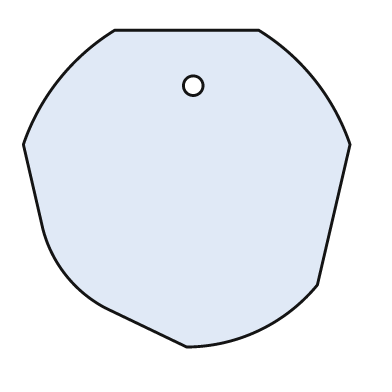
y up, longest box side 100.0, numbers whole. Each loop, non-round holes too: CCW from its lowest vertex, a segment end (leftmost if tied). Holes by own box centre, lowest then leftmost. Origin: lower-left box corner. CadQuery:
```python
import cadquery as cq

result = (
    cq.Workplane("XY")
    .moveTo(50.0, 0.0)
    .threePointArc((72.0, 5.0), (90.0, 19.0))
    .lineTo(100.0, 62.0)
    .threePointArc((89.0, 82.0), (72.0, 97.0))
    .lineTo(28.0, 97.0)
    .threePointArc((11.0, 82.0), (0.0, 62.0))
    .lineTo(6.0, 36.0)
    .threePointArc((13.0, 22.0), (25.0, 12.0))
    .close()
    .moveTo(52.0, 80.0)
    .circle(3.0)
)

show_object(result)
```